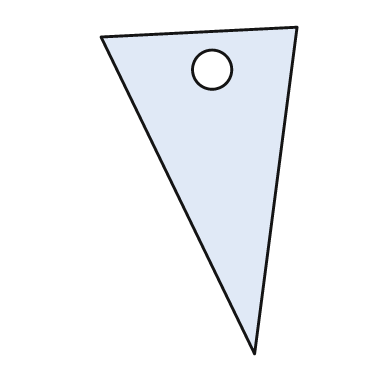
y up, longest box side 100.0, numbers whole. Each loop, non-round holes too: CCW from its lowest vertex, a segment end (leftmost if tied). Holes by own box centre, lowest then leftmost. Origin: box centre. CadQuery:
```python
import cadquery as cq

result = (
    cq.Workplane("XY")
    .moveTo(17.0, -50.0)
    .lineTo(30.0, 50.0)
    .lineTo(-30.0, 47.0)
    .close()
    .moveTo(4.0, 37.0)
    .circle(6.0)
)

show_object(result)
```